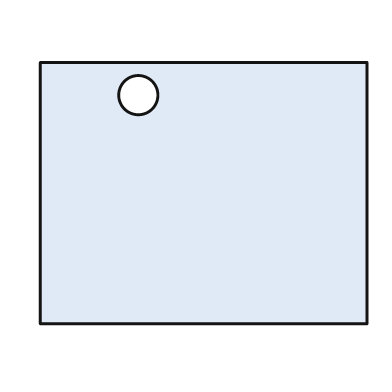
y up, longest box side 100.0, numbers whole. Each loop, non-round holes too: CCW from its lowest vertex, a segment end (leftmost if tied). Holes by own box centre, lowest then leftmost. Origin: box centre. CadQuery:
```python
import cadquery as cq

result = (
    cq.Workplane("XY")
    .moveTo(-50.0, -40.0)
    .lineTo(50.0, -40.0)
    .lineTo(50.0, 40.0)
    .lineTo(-50.0, 40.0)
    .close()
    .moveTo(-20.0, 30.0)
    .circle(6.0)
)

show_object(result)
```